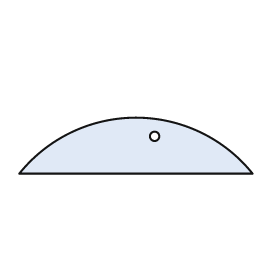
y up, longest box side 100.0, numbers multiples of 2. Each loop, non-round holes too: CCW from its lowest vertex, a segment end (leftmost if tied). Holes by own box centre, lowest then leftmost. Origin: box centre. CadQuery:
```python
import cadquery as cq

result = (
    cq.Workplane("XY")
    .moveTo(-50.0, -12.0)
    .lineTo(50.0, -12.0)
    .threePointArc((0.0, 12.0), (-50.0, -12.0))
    .close()
    .moveTo(8.0, 4.0)
    .circle(2.0)
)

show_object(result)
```